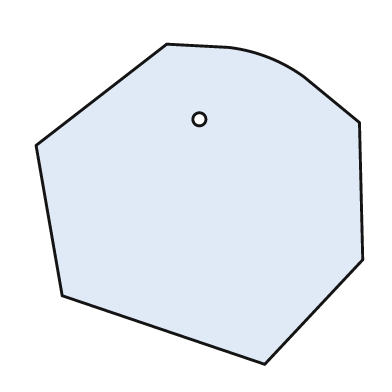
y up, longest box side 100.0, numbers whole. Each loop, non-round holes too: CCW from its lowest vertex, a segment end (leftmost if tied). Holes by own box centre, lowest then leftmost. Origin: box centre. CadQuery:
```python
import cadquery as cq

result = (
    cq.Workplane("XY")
    .moveTo(20.0, -49.0)
    .lineTo(50.0, -17.0)
    .lineTo(49.0, 25.0)
    .lineTo(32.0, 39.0)
    .threePointArc((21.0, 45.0), (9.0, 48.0))
    .lineTo(-10.0, 49.0)
    .lineTo(-50.0, 18.0)
    .lineTo(-42.0, -28.0)
    .close()
    .moveTo(0.0, 26.0)
    .circle(2.0)
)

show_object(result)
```